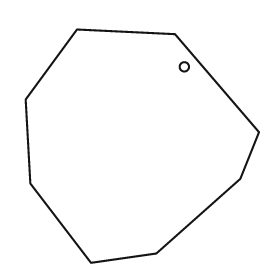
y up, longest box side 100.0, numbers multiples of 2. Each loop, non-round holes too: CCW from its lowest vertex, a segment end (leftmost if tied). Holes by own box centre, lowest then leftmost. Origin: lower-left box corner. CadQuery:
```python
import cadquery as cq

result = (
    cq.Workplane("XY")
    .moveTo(28.0, 0.0)
    .lineTo(56.0, 4.0)
    .lineTo(92.0, 36.0)
    .lineTo(100.0, 56.0)
    .lineTo(64.0, 98.0)
    .lineTo(22.0, 100.0)
    .lineTo(0.0, 70.0)
    .lineTo(2.0, 34.0)
    .close()
    .moveTo(68.0, 84.0)
    .circle(2.0)
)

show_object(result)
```